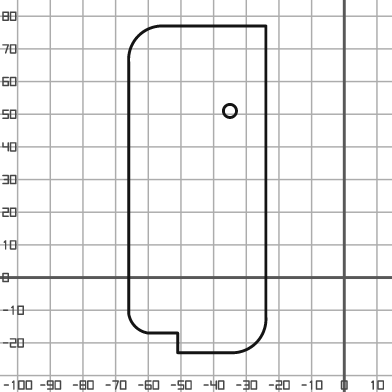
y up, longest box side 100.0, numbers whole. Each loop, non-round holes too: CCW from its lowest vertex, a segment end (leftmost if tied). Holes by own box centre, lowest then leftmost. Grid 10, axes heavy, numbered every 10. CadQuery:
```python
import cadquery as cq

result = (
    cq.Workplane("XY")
    .moveTo(-51.0, -23.0)
    .lineTo(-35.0, -23.0)
    .threePointArc((-27.0, -20.0), (-24.0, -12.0))
    .lineTo(-24.0, 77.0)
    .lineTo(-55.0, 77.0)
    .threePointArc((-63.0, 74.0), (-66.0, 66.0))
    .lineTo(-66.0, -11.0)
    .threePointArc((-64.0, -15.0), (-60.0, -17.0))
    .lineTo(-51.0, -17.0)
    .close()
    .moveTo(-35.0, 51.0)
    .circle(2.0)
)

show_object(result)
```